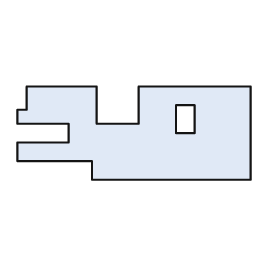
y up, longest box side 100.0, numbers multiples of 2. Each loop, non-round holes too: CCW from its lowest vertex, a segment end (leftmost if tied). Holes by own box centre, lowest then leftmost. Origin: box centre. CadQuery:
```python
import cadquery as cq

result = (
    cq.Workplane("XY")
    .moveTo(-18.0, -20.0)
    .lineTo(50.0, -20.0)
    .lineTo(50.0, 20.0)
    .lineTo(2.0, 20.0)
    .lineTo(2.0, 4.0)
    .lineTo(-16.0, 4.0)
    .lineTo(-16.0, 20.0)
    .lineTo(-46.0, 20.0)
    .lineTo(-46.0, 10.0)
    .lineTo(-50.0, 10.0)
    .lineTo(-50.0, 4.0)
    .lineTo(-28.0, 4.0)
    .lineTo(-28.0, -4.0)
    .lineTo(-50.0, -4.0)
    .lineTo(-50.0, -12.0)
    .lineTo(-18.0, -12.0)
    .close()
    .moveTo(18.0, 0.0)
    .lineTo(26.0, 0.0)
    .lineTo(26.0, 12.0)
    .lineTo(18.0, 12.0)
    .close()
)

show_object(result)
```